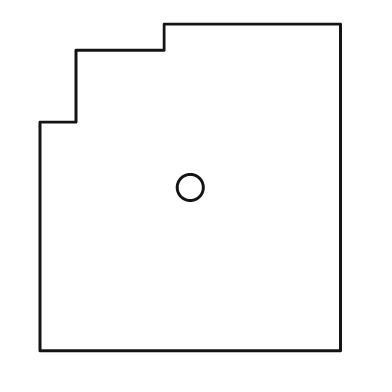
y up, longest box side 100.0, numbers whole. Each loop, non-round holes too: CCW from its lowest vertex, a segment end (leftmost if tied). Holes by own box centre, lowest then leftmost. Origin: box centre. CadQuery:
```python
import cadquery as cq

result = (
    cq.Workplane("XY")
    .moveTo(-46.0, -50.0)
    .lineTo(46.0, -50.0)
    .lineTo(46.0, 50.0)
    .lineTo(-8.0, 50.0)
    .lineTo(-8.0, 42.0)
    .lineTo(-35.0, 42.0)
    .lineTo(-35.0, 20.0)
    .lineTo(-46.0, 20.0)
    .close()
    .moveTo(0.0, 0.0)
    .circle(4.0)
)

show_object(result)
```